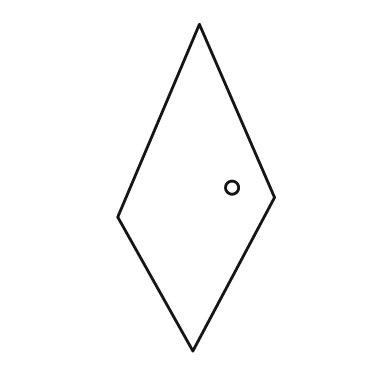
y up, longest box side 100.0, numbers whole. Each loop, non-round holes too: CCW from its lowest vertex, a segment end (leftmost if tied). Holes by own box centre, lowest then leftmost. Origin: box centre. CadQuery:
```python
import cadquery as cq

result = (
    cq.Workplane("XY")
    .moveTo(-1.0, -50.0)
    .lineTo(24.0, -3.0)
    .lineTo(1.0, 50.0)
    .lineTo(-24.0, -9.0)
    .close()
    .moveTo(11.0, 0.0)
    .circle(2.0)
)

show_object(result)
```